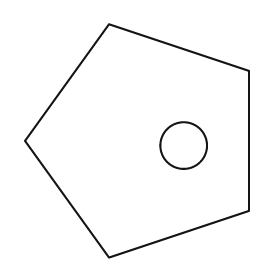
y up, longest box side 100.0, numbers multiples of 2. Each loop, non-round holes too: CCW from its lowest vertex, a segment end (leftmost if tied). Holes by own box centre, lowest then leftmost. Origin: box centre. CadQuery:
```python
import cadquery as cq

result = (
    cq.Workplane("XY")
    .moveTo(-12.0, -50.0)
    .lineTo(48.0, -30.0)
    .lineTo(48.0, 30.0)
    .lineTo(-12.0, 50.0)
    .lineTo(-48.0, 0.0)
    .close()
    .moveTo(20.0, -2.0)
    .circle(10.0)
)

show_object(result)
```